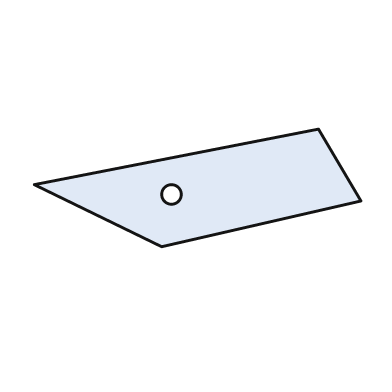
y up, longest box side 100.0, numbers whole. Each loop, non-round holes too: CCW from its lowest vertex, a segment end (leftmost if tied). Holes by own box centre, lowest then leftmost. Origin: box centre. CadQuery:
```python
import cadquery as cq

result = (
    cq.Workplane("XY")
    .moveTo(-11.0, -18.0)
    .lineTo(50.0, -4.0)
    .lineTo(37.0, 18.0)
    .lineTo(-50.0, 1.0)
    .close()
    .moveTo(-8.0, -2.0)
    .circle(3.0)
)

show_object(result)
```